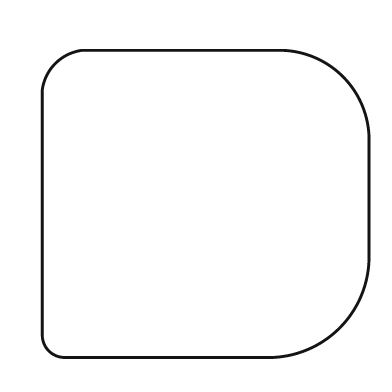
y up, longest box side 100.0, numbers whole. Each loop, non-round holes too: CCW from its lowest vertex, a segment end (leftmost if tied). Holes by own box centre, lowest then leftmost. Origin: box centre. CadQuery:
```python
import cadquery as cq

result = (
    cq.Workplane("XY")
    .moveTo(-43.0, -47.0)
    .lineTo(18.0, -47.0)
    .threePointArc((41.0, -38.0), (50.0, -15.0))
    .lineTo(50.0, 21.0)
    .threePointArc((42.0, 39.0), (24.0, 47.0))
    .lineTo(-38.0, 47.0)
    .threePointArc((-46.0, 43.0), (-50.0, 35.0))
    .lineTo(-50.0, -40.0)
    .threePointArc((-48.0, -45.0), (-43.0, -47.0))
    .close()
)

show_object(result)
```